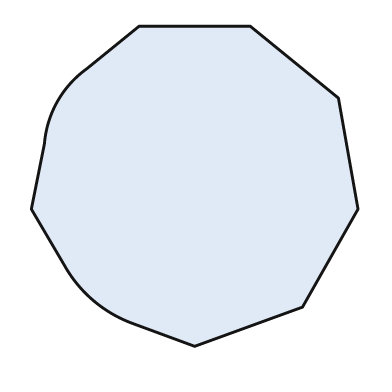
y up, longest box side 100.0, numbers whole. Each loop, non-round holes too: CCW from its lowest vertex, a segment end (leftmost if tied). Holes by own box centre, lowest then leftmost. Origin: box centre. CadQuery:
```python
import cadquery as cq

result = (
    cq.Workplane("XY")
    .moveTo(0.0, -49.0)
    .lineTo(33.0, -37.0)
    .lineTo(50.0, -7.0)
    .lineTo(44.0, 27.0)
    .lineTo(17.0, 49.0)
    .lineTo(-17.0, 49.0)
    .lineTo(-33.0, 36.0)
    .threePointArc((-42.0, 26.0), (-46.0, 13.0))
    .lineTo(-50.0, -7.0)
    .lineTo(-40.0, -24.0)
    .threePointArc((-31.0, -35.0), (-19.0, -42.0))
    .close()
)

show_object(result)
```